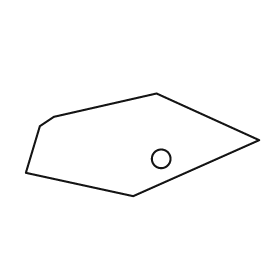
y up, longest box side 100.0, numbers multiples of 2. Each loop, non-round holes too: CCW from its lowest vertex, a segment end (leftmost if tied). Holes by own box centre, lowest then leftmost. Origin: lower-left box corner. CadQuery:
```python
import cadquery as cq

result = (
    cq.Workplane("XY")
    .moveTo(46.0, 0.0)
    .lineTo(100.0, 24.0)
    .lineTo(56.0, 44.0)
    .lineTo(12.0, 34.0)
    .lineTo(6.0, 30.0)
    .lineTo(0.0, 10.0)
    .close()
    .moveTo(58.0, 16.0)
    .circle(4.0)
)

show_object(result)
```